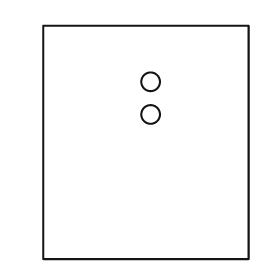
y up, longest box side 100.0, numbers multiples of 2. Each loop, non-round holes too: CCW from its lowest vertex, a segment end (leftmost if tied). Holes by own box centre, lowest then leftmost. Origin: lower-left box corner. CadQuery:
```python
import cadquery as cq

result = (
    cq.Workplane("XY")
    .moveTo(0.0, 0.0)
    .lineTo(88.0, 0.0)
    .lineTo(88.0, 100.0)
    .lineTo(0.0, 100.0)
    .close()
    .moveTo(46.0, 62.0)
    .circle(4.0)
    .moveTo(46.0, 76.0)
    .circle(4.0)
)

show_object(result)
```